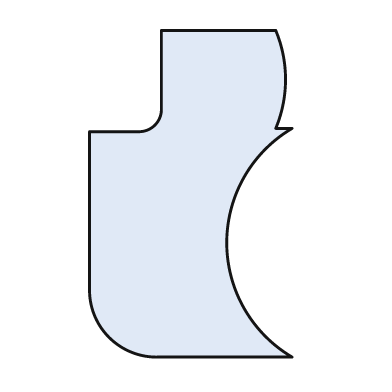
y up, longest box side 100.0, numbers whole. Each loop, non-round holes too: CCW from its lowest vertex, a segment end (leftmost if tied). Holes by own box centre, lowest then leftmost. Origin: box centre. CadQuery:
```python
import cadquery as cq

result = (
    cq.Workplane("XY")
    .moveTo(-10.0, -50.0)
    .lineTo(31.0, -50.0)
    .threePointArc((11.0, -15.0), (31.0, 20.0))
    .lineTo(26.0, 20.0)
    .threePointArc((29.0, 35.0), (26.0, 50.0))
    .lineTo(-9.0, 50.0)
    .lineTo(-9.0, 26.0)
    .threePointArc((-11.0, 21.0), (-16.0, 19.0))
    .lineTo(-31.0, 19.0)
    .lineTo(-31.0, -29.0)
    .threePointArc((-25.0, -44.0), (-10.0, -50.0))
    .close()
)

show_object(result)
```